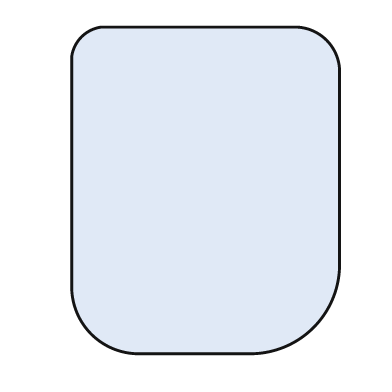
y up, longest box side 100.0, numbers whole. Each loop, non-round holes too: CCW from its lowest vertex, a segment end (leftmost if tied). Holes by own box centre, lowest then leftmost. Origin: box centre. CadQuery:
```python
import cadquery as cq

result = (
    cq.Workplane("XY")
    .moveTo(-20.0, -50.0)
    .lineTo(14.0, -50.0)
    .threePointArc((33.0, -42.0), (41.0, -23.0))
    .lineTo(41.0, 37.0)
    .threePointArc((37.0, 46.0), (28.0, 50.0))
    .lineTo(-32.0, 50.0)
    .threePointArc((-38.0, 47.0), (-41.0, 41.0))
    .lineTo(-41.0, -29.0)
    .threePointArc((-35.0, -44.0), (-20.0, -50.0))
    .close()
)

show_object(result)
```